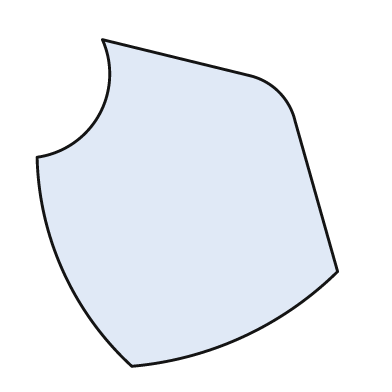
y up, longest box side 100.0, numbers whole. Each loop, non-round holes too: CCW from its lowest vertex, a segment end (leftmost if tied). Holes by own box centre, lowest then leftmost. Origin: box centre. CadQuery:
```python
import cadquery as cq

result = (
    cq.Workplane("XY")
    .moveTo(-17.0, -50.0)
    .threePointArc((17.0, -41.0), (46.0, -21.0))
    .lineTo(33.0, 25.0)
    .threePointArc((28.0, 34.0), (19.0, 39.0))
    .lineTo(-26.0, 50.0)
    .threePointArc((-27.0, 27.0), (-46.0, 14.0))
    .threePointArc((-38.0, -21.0), (-17.0, -50.0))
    .close()
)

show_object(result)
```